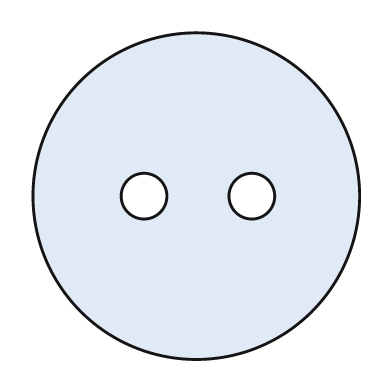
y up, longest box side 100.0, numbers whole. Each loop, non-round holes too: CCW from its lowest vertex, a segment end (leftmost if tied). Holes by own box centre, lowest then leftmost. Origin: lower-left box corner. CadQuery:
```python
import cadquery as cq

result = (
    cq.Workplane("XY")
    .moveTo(50.0, 50.0)
    .circle(50.0)
    .moveTo(34.0, 50.0)
    .circle(7.0)
    .moveTo(67.0, 50.0)
    .circle(7.0)
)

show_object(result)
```